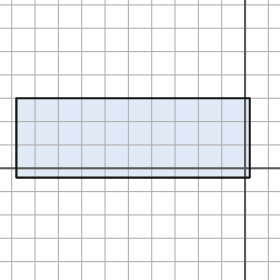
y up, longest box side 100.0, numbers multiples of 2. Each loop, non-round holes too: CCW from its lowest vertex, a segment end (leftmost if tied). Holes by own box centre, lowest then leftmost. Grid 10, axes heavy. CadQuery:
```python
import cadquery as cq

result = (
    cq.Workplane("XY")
    .moveTo(-98.0, -4.0)
    .lineTo(2.0, -4.0)
    .lineTo(2.0, 30.0)
    .lineTo(-98.0, 30.0)
    .close()
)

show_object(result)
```